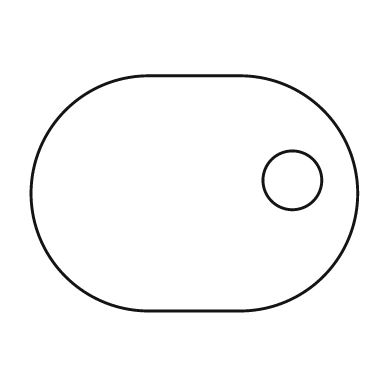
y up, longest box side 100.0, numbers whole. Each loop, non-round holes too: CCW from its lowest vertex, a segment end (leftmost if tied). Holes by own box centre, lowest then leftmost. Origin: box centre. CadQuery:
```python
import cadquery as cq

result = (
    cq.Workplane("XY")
    .moveTo(-14.0, -36.0)
    .lineTo(14.0, -36.0)
    .threePointArc((50.0, 0.0), (14.0, 36.0))
    .lineTo(-14.0, 36.0)
    .threePointArc((-50.0, 0.0), (-14.0, -36.0))
    .close()
    .moveTo(30.0, 4.0)
    .circle(9.0)
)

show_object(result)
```